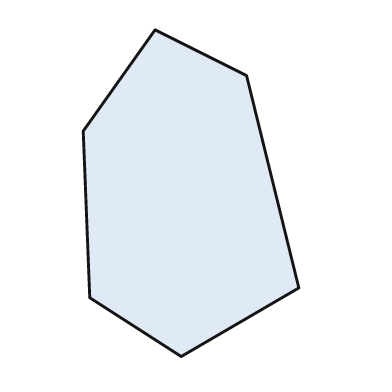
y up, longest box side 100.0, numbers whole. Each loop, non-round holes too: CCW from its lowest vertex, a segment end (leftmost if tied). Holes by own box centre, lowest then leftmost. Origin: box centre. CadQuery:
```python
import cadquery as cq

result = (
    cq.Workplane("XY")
    .moveTo(-3.0, -50.0)
    .lineTo(33.0, -29.0)
    .lineTo(17.0, 36.0)
    .lineTo(-11.0, 50.0)
    .lineTo(-33.0, 19.0)
    .lineTo(-31.0, -32.0)
    .close()
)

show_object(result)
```